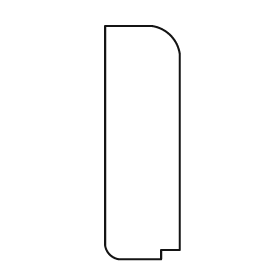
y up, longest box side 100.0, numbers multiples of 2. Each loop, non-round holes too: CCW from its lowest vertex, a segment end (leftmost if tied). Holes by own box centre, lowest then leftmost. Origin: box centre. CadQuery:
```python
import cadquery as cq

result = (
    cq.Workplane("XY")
    .moveTo(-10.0, -50.0)
    .lineTo(8.0, -50.0)
    .lineTo(8.0, -46.0)
    .lineTo(16.0, -46.0)
    .lineTo(16.0, 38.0)
    .threePointArc((12.0, 46.0), (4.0, 50.0))
    .lineTo(-16.0, 50.0)
    .lineTo(-16.0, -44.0)
    .threePointArc((-14.0, -48.0), (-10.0, -50.0))
    .close()
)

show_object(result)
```